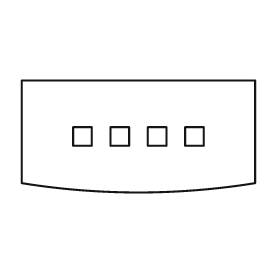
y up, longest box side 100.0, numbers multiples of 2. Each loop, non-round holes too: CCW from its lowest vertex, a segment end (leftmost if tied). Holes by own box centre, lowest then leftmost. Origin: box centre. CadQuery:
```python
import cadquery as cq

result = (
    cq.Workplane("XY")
    .moveTo(-50.0, -20.0)
    .threePointArc((0.0, -24.0), (50.0, -20.0))
    .lineTo(50.0, 24.0)
    .lineTo(-50.0, 24.0)
    .close()
    .moveTo(-28.0, -4.0)
    .lineTo(-20.0, -4.0)
    .lineTo(-20.0, 4.0)
    .lineTo(-28.0, 4.0)
    .close()
    .moveTo(-12.0, -4.0)
    .lineTo(-4.0, -4.0)
    .lineTo(-4.0, 4.0)
    .lineTo(-12.0, 4.0)
    .close()
    .moveTo(4.0, -4.0)
    .lineTo(12.0, -4.0)
    .lineTo(12.0, 4.0)
    .lineTo(4.0, 4.0)
    .close()
    .moveTo(20.0, -4.0)
    .lineTo(28.0, -4.0)
    .lineTo(28.0, 4.0)
    .lineTo(20.0, 4.0)
    .close()
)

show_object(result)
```